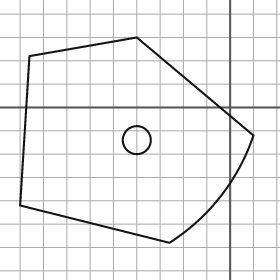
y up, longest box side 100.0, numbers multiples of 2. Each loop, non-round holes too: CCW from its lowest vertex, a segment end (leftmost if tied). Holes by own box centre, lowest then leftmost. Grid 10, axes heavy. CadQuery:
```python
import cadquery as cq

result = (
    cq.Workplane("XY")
    .moveTo(-26.0, -58.0)
    .threePointArc((-4.0, -38.0), (10.0, -12.0))
    .lineTo(-40.0, 30.0)
    .lineTo(-86.0, 22.0)
    .lineTo(-90.0, -42.0)
    .close()
    .moveTo(-40.0, -14.0)
    .circle(6.0)
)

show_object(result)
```